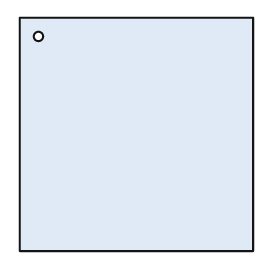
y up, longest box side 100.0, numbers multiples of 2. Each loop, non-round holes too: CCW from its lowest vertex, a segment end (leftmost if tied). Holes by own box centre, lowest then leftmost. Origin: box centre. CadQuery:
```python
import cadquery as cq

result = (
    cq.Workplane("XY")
    .moveTo(-50.0, -50.0)
    .lineTo(50.0, -50.0)
    .lineTo(50.0, 50.0)
    .lineTo(-50.0, 50.0)
    .close()
    .moveTo(-42.0, 42.0)
    .circle(2.0)
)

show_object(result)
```